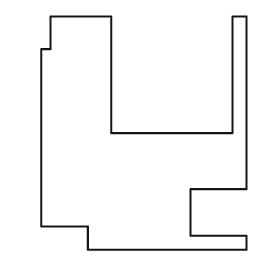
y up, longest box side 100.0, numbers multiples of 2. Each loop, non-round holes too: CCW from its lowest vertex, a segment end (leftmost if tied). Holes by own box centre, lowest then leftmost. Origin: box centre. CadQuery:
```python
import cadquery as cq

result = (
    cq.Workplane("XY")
    .moveTo(-24.0, -50.0)
    .lineTo(44.0, -50.0)
    .lineTo(44.0, -44.0)
    .lineTo(20.0, -44.0)
    .lineTo(20.0, -24.0)
    .lineTo(44.0, -24.0)
    .lineTo(44.0, 50.0)
    .lineTo(38.0, 50.0)
    .lineTo(38.0, 0.0)
    .lineTo(-14.0, 0.0)
    .lineTo(-14.0, 50.0)
    .lineTo(-40.0, 50.0)
    .lineTo(-40.0, 36.0)
    .lineTo(-44.0, 36.0)
    .lineTo(-44.0, -40.0)
    .lineTo(-24.0, -40.0)
    .close()
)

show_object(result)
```